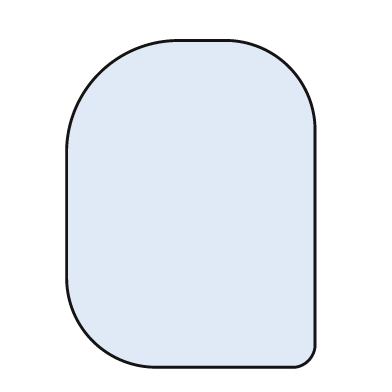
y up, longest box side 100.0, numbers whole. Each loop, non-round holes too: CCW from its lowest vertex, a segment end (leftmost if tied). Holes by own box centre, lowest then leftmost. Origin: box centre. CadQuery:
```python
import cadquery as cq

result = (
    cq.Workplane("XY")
    .moveTo(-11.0, -50.0)
    .lineTo(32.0, -50.0)
    .threePointArc((36.0, -48.0), (38.0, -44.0))
    .lineTo(38.0, 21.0)
    .threePointArc((30.0, 42.0), (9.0, 50.0))
    .lineTo(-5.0, 50.0)
    .threePointArc((-28.0, 40.0), (-38.0, 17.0))
    .lineTo(-38.0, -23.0)
    .threePointArc((-30.0, -42.0), (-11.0, -50.0))
    .close()
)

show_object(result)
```